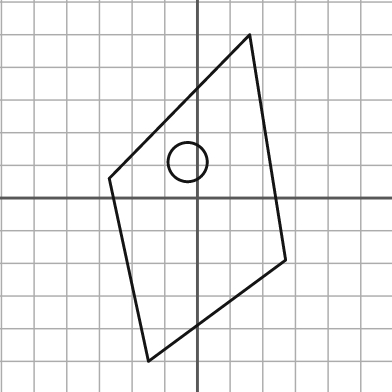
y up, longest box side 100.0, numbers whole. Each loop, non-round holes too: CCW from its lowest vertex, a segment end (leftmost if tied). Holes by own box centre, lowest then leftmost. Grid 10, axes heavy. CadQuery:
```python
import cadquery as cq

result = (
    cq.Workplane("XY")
    .moveTo(-15.0, -50.0)
    .lineTo(27.0, -19.0)
    .lineTo(16.0, 50.0)
    .lineTo(-27.0, 6.0)
    .close()
    .moveTo(-3.0, 11.0)
    .circle(6.0)
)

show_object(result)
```